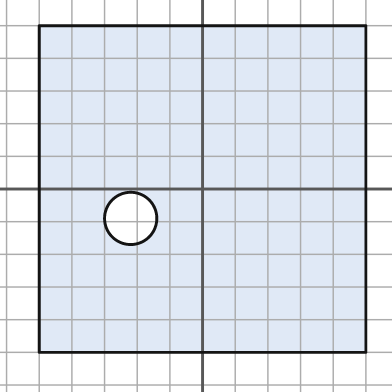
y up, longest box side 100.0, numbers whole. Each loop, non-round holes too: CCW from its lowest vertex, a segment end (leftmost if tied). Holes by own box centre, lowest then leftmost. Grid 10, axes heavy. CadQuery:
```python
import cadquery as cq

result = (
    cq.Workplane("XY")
    .moveTo(-50.0, -50.0)
    .lineTo(50.0, -50.0)
    .lineTo(50.0, 50.0)
    .lineTo(-50.0, 50.0)
    .close()
    .moveTo(-22.0, -9.0)
    .circle(8.0)
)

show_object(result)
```